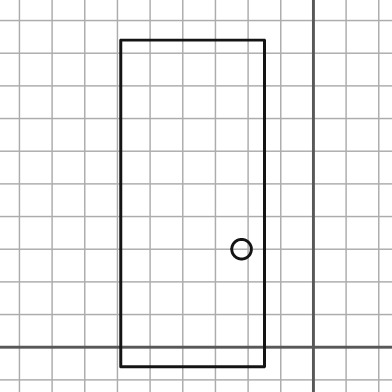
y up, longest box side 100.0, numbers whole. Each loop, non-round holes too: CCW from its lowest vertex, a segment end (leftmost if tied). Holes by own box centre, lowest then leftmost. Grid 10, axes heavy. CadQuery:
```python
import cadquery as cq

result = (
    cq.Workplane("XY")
    .moveTo(-59.0, -6.0)
    .lineTo(-15.0, -6.0)
    .lineTo(-15.0, 94.0)
    .lineTo(-59.0, 94.0)
    .close()
    .moveTo(-22.0, 30.0)
    .circle(3.0)
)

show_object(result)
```